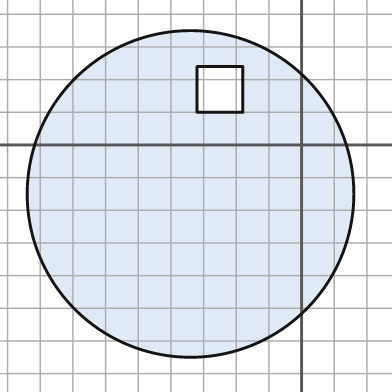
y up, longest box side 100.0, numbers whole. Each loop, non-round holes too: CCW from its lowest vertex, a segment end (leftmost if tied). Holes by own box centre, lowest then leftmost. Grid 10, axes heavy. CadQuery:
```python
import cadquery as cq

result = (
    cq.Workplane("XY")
    .moveTo(-34.0, -15.0)
    .circle(50.0)
    .moveTo(-32.0, 10.0)
    .lineTo(-18.0, 10.0)
    .lineTo(-18.0, 24.0)
    .lineTo(-32.0, 24.0)
    .close()
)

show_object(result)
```